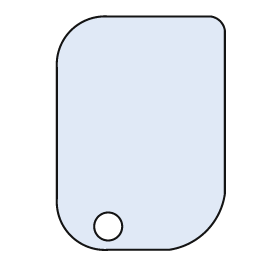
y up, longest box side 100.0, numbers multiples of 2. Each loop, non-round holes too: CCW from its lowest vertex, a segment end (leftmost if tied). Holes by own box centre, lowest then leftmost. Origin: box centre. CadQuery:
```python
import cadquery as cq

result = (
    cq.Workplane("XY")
    .moveTo(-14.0, -50.0)
    .lineTo(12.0, -50.0)
    .threePointArc((28.0, -42.0), (36.0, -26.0))
    .lineTo(36.0, 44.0)
    .threePointArc((34.0, 48.0), (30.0, 50.0))
    .lineTo(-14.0, 50.0)
    .threePointArc((-30.0, 44.0), (-36.0, 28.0))
    .lineTo(-36.0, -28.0)
    .threePointArc((-30.0, -44.0), (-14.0, -50.0))
    .close()
    .moveTo(-14.0, -40.0)
    .circle(6.0)
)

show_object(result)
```